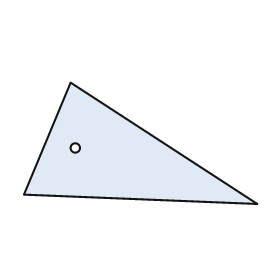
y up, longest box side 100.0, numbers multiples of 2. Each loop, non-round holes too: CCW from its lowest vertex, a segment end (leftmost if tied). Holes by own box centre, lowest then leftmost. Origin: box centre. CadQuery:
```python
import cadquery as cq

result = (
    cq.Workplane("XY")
    .moveTo(50.0, -26.0)
    .lineTo(-30.0, 26.0)
    .lineTo(-50.0, -22.0)
    .close()
    .moveTo(-28.0, -2.0)
    .circle(2.0)
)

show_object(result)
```